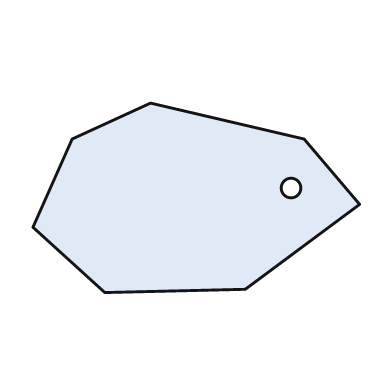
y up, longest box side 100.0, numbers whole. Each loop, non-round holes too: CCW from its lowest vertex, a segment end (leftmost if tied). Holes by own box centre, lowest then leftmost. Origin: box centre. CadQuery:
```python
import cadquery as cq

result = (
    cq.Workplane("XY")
    .moveTo(-28.0, -29.0)
    .lineTo(15.0, -28.0)
    .lineTo(50.0, -2.0)
    .lineTo(33.0, 18.0)
    .lineTo(-14.0, 29.0)
    .lineTo(-38.0, 18.0)
    .lineTo(-50.0, -9.0)
    .close()
    .moveTo(29.0, 3.0)
    .circle(3.0)
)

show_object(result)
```